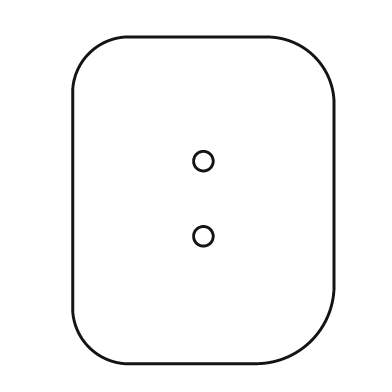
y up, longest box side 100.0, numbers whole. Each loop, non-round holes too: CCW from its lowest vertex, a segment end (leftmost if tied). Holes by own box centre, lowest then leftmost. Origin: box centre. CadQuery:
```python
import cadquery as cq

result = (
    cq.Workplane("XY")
    .moveTo(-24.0, -50.0)
    .lineTo(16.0, -50.0)
    .threePointArc((33.0, -43.0), (40.0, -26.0))
    .lineTo(40.0, 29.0)
    .threePointArc((34.0, 44.0), (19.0, 50.0))
    .lineTo(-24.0, 50.0)
    .threePointArc((-35.0, 45.0), (-40.0, 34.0))
    .lineTo(-40.0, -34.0)
    .threePointArc((-35.0, -45.0), (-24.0, -50.0))
    .close()
    .moveTo(0.0, -11.0)
    .circle(3.0)
    .moveTo(0.0, 12.0)
    .circle(3.0)
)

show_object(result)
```